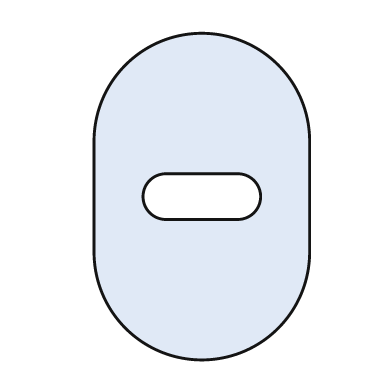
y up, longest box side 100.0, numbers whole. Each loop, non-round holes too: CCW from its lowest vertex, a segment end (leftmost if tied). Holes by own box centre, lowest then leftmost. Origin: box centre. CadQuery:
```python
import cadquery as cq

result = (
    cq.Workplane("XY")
    .moveTo(-33.0, -17.0)
    .threePointArc((0.0, -50.0), (33.0, -17.0))
    .lineTo(33.0, 17.0)
    .threePointArc((0.0, 50.0), (-33.0, 17.0))
    .close()
    .moveTo(-11.0, -7.0)
    .lineTo(11.0, -7.0)
    .threePointArc((18.0, 0.0), (11.0, 7.0))
    .lineTo(-11.0, 7.0)
    .threePointArc((-18.0, 0.0), (-11.0, -7.0))
    .close()
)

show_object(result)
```